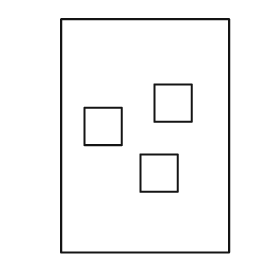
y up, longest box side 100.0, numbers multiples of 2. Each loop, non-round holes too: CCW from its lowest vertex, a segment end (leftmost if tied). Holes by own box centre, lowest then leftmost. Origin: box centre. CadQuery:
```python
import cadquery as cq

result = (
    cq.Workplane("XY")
    .moveTo(-36.0, -50.0)
    .lineTo(36.0, -50.0)
    .lineTo(36.0, 50.0)
    .lineTo(-36.0, 50.0)
    .close()
    .moveTo(-2.0, -24.0)
    .lineTo(14.0, -24.0)
    .lineTo(14.0, -8.0)
    .lineTo(-2.0, -8.0)
    .close()
    .moveTo(-26.0, -4.0)
    .lineTo(-10.0, -4.0)
    .lineTo(-10.0, 12.0)
    .lineTo(-26.0, 12.0)
    .close()
    .moveTo(4.0, 6.0)
    .lineTo(20.0, 6.0)
    .lineTo(20.0, 22.0)
    .lineTo(4.0, 22.0)
    .close()
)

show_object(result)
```